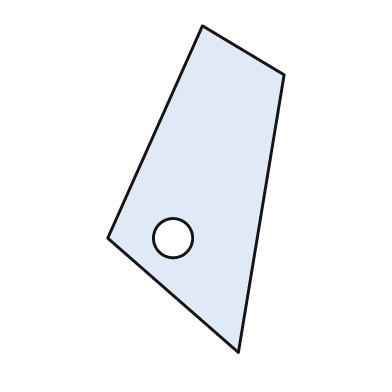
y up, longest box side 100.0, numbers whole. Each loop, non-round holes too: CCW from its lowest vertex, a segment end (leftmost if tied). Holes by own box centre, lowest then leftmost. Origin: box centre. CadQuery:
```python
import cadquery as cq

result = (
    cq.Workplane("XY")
    .moveTo(13.0, -50.0)
    .lineTo(27.0, 35.0)
    .lineTo(2.0, 50.0)
    .lineTo(-27.0, -15.0)
    .close()
    .moveTo(-7.0, -15.0)
    .circle(6.0)
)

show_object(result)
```